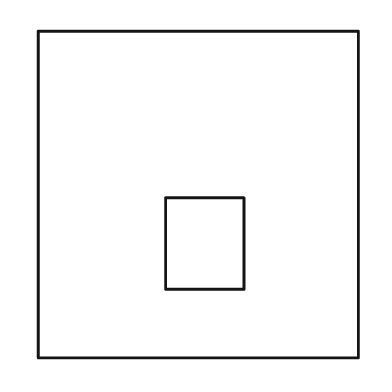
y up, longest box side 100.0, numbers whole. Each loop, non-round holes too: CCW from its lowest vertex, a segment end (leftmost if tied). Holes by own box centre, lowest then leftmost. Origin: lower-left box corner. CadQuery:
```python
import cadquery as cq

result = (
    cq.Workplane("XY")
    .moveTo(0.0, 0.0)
    .lineTo(98.0, 0.0)
    .lineTo(98.0, 100.0)
    .lineTo(0.0, 100.0)
    .close()
    .moveTo(39.0, 21.0)
    .lineTo(63.0, 21.0)
    .lineTo(63.0, 49.0)
    .lineTo(39.0, 49.0)
    .close()
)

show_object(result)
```